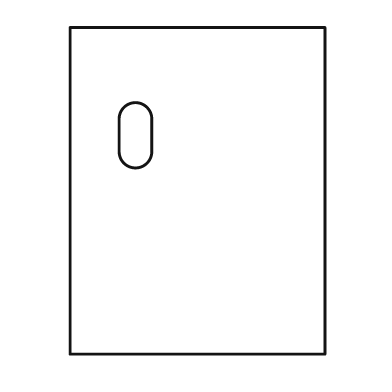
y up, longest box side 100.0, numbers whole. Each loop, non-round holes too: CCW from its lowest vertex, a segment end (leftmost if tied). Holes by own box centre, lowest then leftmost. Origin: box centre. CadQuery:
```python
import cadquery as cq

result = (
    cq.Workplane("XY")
    .moveTo(-39.0, -50.0)
    .lineTo(39.0, -50.0)
    .lineTo(39.0, 50.0)
    .lineTo(-39.0, 50.0)
    .close()
    .moveTo(-24.0, 12.0)
    .threePointArc((-19.0, 7.0), (-14.0, 12.0))
    .lineTo(-14.0, 22.0)
    .threePointArc((-19.0, 27.0), (-24.0, 22.0))
    .close()
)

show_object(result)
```